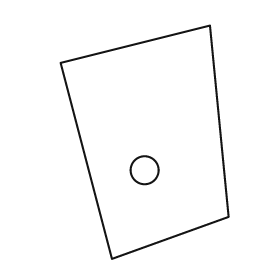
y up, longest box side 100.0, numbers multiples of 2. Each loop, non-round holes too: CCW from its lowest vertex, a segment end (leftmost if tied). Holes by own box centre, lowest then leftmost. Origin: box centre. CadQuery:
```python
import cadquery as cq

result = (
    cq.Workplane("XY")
    .moveTo(-14.0, -50.0)
    .lineTo(36.0, -32.0)
    .lineTo(28.0, 50.0)
    .lineTo(-36.0, 34.0)
    .close()
    .moveTo(0.0, -12.0)
    .circle(6.0)
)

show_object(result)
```